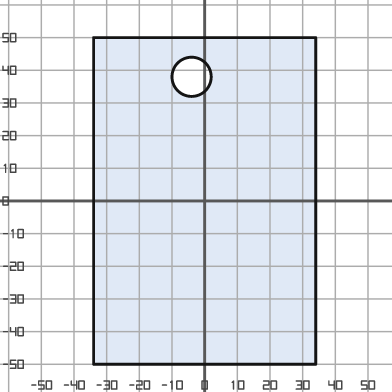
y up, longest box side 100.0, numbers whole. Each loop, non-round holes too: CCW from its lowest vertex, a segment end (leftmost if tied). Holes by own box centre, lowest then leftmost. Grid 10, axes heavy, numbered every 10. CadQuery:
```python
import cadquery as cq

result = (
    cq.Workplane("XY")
    .moveTo(-34.0, -50.0)
    .lineTo(34.0, -50.0)
    .lineTo(34.0, 50.0)
    .lineTo(-34.0, 50.0)
    .close()
    .moveTo(-4.0, 38.0)
    .circle(6.0)
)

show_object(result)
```